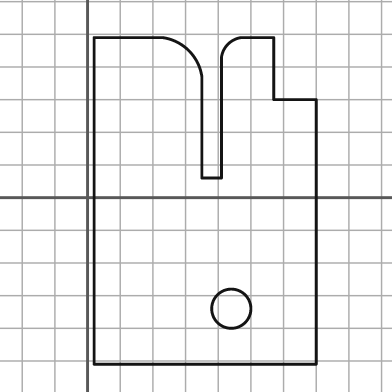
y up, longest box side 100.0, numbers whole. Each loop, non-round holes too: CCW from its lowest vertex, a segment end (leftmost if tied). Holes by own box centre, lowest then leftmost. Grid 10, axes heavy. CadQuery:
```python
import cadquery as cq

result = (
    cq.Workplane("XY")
    .moveTo(2.0, -51.0)
    .lineTo(70.0, -51.0)
    .lineTo(70.0, 30.0)
    .lineTo(57.0, 30.0)
    .lineTo(57.0, 49.0)
    .lineTo(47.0, 49.0)
    .threePointArc((43.0, 47.0), (41.0, 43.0))
    .lineTo(41.0, 6.0)
    .lineTo(35.0, 6.0)
    .lineTo(35.0, 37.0)
    .threePointArc((31.0, 45.0), (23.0, 49.0))
    .lineTo(2.0, 49.0)
    .close()
    .moveTo(44.0, -34.0)
    .circle(6.0)
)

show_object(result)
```